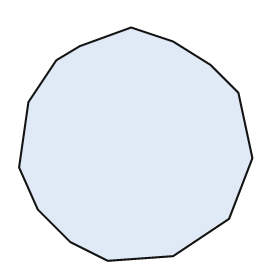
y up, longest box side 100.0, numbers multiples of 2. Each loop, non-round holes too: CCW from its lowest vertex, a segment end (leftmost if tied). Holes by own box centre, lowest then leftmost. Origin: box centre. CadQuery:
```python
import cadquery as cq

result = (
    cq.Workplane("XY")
    .moveTo(-12.0, -50.0)
    .lineTo(16.0, -48.0)
    .lineTo(40.0, -32.0)
    .lineTo(50.0, -6.0)
    .lineTo(44.0, 22.0)
    .lineTo(32.0, 34.0)
    .lineTo(16.0, 44.0)
    .lineTo(-2.0, 50.0)
    .lineTo(-24.0, 42.0)
    .lineTo(-34.0, 36.0)
    .lineTo(-46.0, 18.0)
    .lineTo(-50.0, -10.0)
    .lineTo(-42.0, -28.0)
    .lineTo(-28.0, -42.0)
    .close()
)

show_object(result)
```